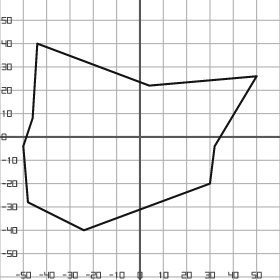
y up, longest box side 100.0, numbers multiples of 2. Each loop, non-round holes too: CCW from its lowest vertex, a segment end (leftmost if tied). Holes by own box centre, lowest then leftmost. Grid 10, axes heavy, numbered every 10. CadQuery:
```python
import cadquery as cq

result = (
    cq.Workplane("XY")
    .moveTo(-24.0, -40.0)
    .lineTo(30.0, -20.0)
    .lineTo(32.0, -4.0)
    .lineTo(50.0, 26.0)
    .lineTo(4.0, 22.0)
    .lineTo(-44.0, 40.0)
    .lineTo(-46.0, 8.0)
    .lineTo(-50.0, -4.0)
    .lineTo(-48.0, -28.0)
    .close()
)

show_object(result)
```